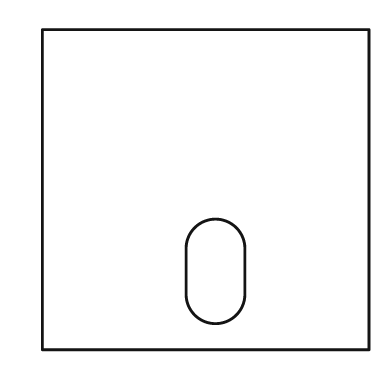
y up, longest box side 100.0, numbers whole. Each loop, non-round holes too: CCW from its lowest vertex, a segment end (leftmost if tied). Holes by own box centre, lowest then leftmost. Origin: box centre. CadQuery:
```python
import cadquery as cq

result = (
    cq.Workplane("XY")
    .moveTo(-50.0, -49.0)
    .lineTo(50.0, -49.0)
    .lineTo(50.0, 49.0)
    .lineTo(-50.0, 49.0)
    .close()
    .moveTo(-6.0, -32.0)
    .threePointArc((3.0, -41.0), (12.0, -32.0))
    .lineTo(12.0, -18.0)
    .threePointArc((3.0, -9.0), (-6.0, -18.0))
    .close()
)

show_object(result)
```